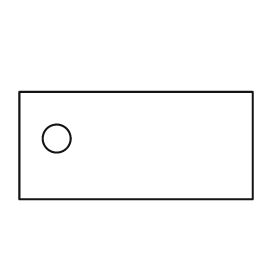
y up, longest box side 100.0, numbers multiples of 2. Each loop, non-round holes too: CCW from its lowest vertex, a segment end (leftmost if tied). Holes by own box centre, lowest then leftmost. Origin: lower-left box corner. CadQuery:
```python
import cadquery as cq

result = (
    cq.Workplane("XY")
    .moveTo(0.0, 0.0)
    .lineTo(100.0, 0.0)
    .lineTo(100.0, 46.0)
    .lineTo(0.0, 46.0)
    .close()
    .moveTo(16.0, 26.0)
    .circle(6.0)
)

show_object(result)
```